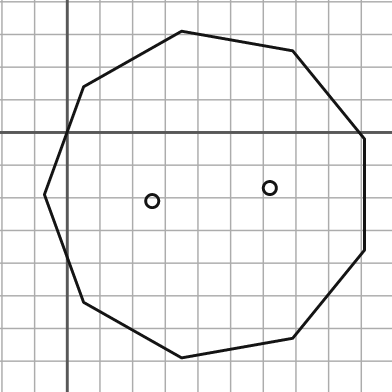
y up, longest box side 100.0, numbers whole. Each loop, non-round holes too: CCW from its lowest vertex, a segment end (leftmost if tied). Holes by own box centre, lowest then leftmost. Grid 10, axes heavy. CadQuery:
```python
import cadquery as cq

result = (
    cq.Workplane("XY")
    .moveTo(35.0, -69.0)
    .lineTo(69.0, -63.0)
    .lineTo(91.0, -36.0)
    .lineTo(91.0, -2.0)
    .lineTo(69.0, 25.0)
    .lineTo(35.0, 31.0)
    .lineTo(5.0, 14.0)
    .lineTo(-7.0, -19.0)
    .lineTo(5.0, -52.0)
    .close()
    .moveTo(26.0, -21.0)
    .circle(2.0)
    .moveTo(62.0, -17.0)
    .circle(2.0)
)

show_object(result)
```